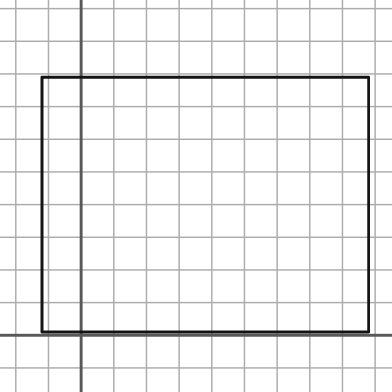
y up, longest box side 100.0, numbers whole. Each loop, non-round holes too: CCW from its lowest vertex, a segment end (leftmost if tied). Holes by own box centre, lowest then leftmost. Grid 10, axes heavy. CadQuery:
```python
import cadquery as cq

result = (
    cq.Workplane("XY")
    .moveTo(-12.0, 1.0)
    .lineTo(88.0, 1.0)
    .lineTo(88.0, 79.0)
    .lineTo(-12.0, 79.0)
    .close()
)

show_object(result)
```